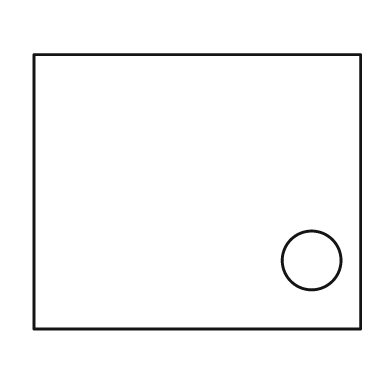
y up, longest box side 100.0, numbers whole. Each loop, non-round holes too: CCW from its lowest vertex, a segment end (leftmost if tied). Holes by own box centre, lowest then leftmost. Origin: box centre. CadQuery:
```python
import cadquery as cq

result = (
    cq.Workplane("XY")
    .moveTo(-50.0, -42.0)
    .lineTo(50.0, -42.0)
    .lineTo(50.0, 42.0)
    .lineTo(-50.0, 42.0)
    .close()
    .moveTo(35.0, -21.0)
    .circle(9.0)
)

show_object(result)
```